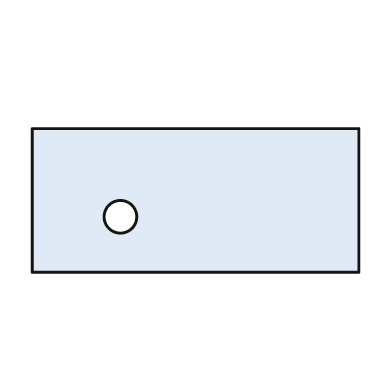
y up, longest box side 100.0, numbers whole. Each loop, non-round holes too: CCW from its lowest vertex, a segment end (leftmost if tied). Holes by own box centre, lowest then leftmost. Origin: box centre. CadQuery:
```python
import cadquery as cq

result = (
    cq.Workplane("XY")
    .moveTo(-50.0, -22.0)
    .lineTo(50.0, -22.0)
    .lineTo(50.0, 22.0)
    .lineTo(-50.0, 22.0)
    .close()
    .moveTo(-23.0, -5.0)
    .circle(5.0)
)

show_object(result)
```